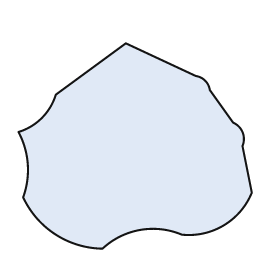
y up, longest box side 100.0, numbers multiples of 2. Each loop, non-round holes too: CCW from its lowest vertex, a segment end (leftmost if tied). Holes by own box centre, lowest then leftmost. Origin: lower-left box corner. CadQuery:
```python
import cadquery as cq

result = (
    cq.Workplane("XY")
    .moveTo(36.0, 0.0)
    .threePointArc((52.0, 8.0), (70.0, 6.0))
    .threePointArc((88.0, 10.0), (100.0, 24.0))
    .lineTo(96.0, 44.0)
    .threePointArc((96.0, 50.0), (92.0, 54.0))
    .lineTo(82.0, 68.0)
    .threePointArc((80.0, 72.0), (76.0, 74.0))
    .lineTo(46.0, 88.0)
    .lineTo(16.0, 66.0)
    .threePointArc((10.0, 56.0), (0.0, 50.0))
    .threePointArc((4.0, 36.0), (2.0, 22.0))
    .threePointArc((16.0, 6.0), (36.0, 0.0))
    .close()
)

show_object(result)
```